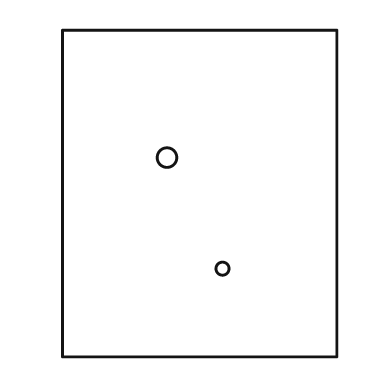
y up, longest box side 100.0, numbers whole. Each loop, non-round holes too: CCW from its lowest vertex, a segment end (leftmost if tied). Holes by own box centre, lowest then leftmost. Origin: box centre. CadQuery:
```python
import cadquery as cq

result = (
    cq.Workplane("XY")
    .moveTo(-42.0, -50.0)
    .lineTo(42.0, -50.0)
    .lineTo(42.0, 50.0)
    .lineTo(-42.0, 50.0)
    .close()
    .moveTo(7.0, -23.0)
    .circle(2.0)
    .moveTo(-10.0, 11.0)
    .circle(3.0)
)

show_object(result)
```